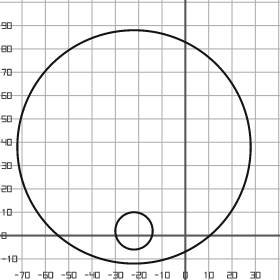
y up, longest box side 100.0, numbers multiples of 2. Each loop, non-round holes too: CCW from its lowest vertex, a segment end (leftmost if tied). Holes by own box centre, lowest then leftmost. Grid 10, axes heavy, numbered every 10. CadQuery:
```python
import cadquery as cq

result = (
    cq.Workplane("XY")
    .moveTo(-22.0, 38.0)
    .circle(50.0)
    .moveTo(-22.0, 2.0)
    .circle(8.0)
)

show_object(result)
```